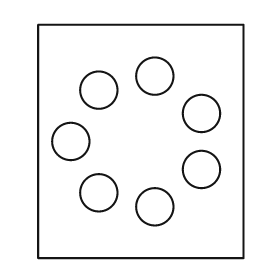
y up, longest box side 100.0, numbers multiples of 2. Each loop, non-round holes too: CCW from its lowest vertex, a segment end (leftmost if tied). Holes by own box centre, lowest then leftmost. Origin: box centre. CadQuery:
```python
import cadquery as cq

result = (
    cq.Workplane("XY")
    .moveTo(-44.0, -50.0)
    .lineTo(44.0, -50.0)
    .lineTo(44.0, 50.0)
    .lineTo(-44.0, 50.0)
    .close()
    .moveTo(6.0, -28.0)
    .circle(8.0)
    .moveTo(-18.0, -22.0)
    .circle(8.0)
    .moveTo(26.0, -12.0)
    .circle(8.0)
    .moveTo(-30.0, 0.0)
    .circle(8.0)
    .moveTo(26.0, 12.0)
    .circle(8.0)
    .moveTo(-18.0, 22.0)
    .circle(8.0)
    .moveTo(6.0, 28.0)
    .circle(8.0)
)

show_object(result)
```